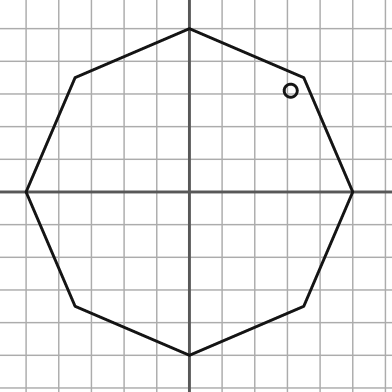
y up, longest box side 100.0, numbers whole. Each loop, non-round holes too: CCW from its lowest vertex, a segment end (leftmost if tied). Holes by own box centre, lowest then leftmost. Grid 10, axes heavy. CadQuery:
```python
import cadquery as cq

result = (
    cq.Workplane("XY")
    .moveTo(0.0, -50.0)
    .lineTo(35.0, -35.0)
    .lineTo(50.0, 0.0)
    .lineTo(35.0, 35.0)
    .lineTo(0.0, 50.0)
    .lineTo(-35.0, 35.0)
    .lineTo(-50.0, 0.0)
    .lineTo(-35.0, -35.0)
    .close()
    .moveTo(31.0, 31.0)
    .circle(2.0)
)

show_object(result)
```